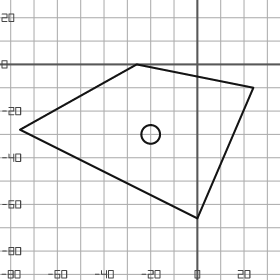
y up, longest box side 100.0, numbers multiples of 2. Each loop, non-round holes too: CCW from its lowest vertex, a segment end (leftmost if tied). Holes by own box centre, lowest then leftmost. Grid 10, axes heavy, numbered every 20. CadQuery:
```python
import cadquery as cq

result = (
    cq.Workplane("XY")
    .moveTo(0.0, -66.0)
    .lineTo(24.0, -10.0)
    .lineTo(-26.0, 0.0)
    .lineTo(-76.0, -28.0)
    .close()
    .moveTo(-20.0, -30.0)
    .circle(4.0)
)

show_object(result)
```